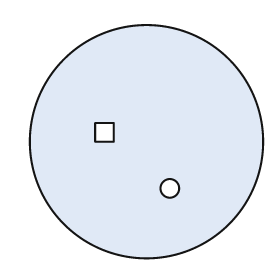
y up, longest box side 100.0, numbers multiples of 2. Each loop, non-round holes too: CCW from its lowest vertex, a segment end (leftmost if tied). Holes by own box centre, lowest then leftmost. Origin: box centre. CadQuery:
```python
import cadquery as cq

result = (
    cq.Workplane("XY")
    .moveTo(0.0, 0.0)
    .circle(50.0)
    .moveTo(10.0, -20.0)
    .circle(4.0)
    .moveTo(-22.0, 0.0)
    .lineTo(-14.0, 0.0)
    .lineTo(-14.0, 8.0)
    .lineTo(-22.0, 8.0)
    .close()
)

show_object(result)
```